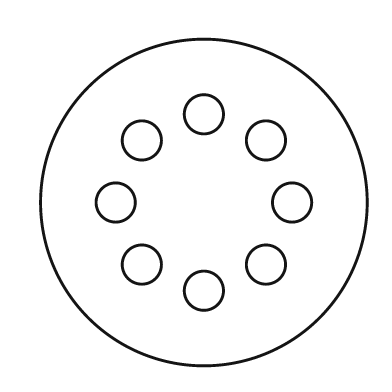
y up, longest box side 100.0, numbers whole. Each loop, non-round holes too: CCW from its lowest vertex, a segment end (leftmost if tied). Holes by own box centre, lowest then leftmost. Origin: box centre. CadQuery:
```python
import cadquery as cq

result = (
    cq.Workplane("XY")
    .moveTo(0.0, 0.0)
    .circle(50.0)
    .moveTo(0.0, -27.0)
    .circle(6.0)
    .moveTo(-19.0, -19.0)
    .circle(6.0)
    .moveTo(19.0, -19.0)
    .circle(6.0)
    .moveTo(-27.0, 0.0)
    .circle(6.0)
    .moveTo(27.0, 0.0)
    .circle(6.0)
    .moveTo(-19.0, 19.0)
    .circle(6.0)
    .moveTo(19.0, 19.0)
    .circle(6.0)
    .moveTo(0.0, 27.0)
    .circle(6.0)
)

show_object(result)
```